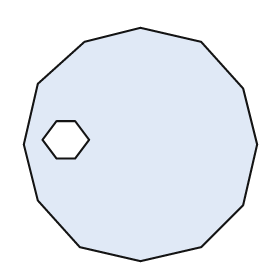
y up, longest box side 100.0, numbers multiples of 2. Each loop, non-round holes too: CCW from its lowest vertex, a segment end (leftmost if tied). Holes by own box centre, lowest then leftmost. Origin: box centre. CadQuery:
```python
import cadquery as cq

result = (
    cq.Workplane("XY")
    .moveTo(0.0, -50.0)
    .lineTo(26.0, -44.0)
    .lineTo(44.0, -26.0)
    .lineTo(50.0, 0.0)
    .lineTo(44.0, 24.0)
    .lineTo(26.0, 44.0)
    .lineTo(0.0, 50.0)
    .lineTo(-24.0, 44.0)
    .lineTo(-44.0, 26.0)
    .lineTo(-50.0, 0.0)
    .lineTo(-44.0, -24.0)
    .lineTo(-26.0, -44.0)
    .close()
    .moveTo(-36.0, -6.0)
    .lineTo(-28.0, -6.0)
    .lineTo(-22.0, 2.0)
    .lineTo(-28.0, 10.0)
    .lineTo(-36.0, 10.0)
    .lineTo(-42.0, 2.0)
    .close()
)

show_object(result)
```